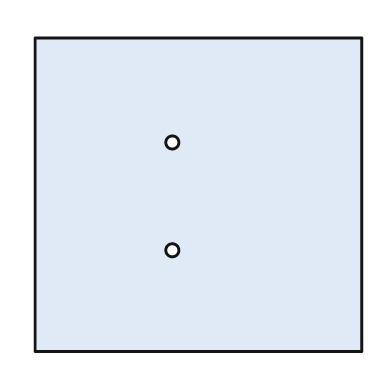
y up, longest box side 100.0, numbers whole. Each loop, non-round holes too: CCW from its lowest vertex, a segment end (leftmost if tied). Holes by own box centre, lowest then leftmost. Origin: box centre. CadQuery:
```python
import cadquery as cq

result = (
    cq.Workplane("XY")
    .moveTo(-50.0, -48.0)
    .lineTo(50.0, -48.0)
    .lineTo(50.0, 48.0)
    .lineTo(-50.0, 48.0)
    .close()
    .moveTo(-8.0, -17.0)
    .circle(2.0)
    .moveTo(-8.0, 16.0)
    .circle(2.0)
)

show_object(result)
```